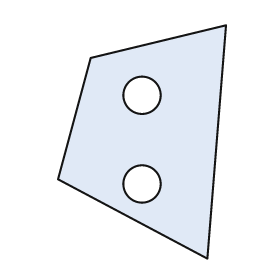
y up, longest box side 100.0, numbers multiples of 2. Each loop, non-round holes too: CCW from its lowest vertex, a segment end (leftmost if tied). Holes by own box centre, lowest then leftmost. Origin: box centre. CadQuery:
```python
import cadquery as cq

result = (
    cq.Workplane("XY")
    .moveTo(28.0, -50.0)
    .lineTo(36.0, 50.0)
    .lineTo(-22.0, 36.0)
    .lineTo(-36.0, -16.0)
    .close()
    .moveTo(0.0, -18.0)
    .circle(8.0)
    .moveTo(0.0, 20.0)
    .circle(8.0)
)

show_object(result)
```